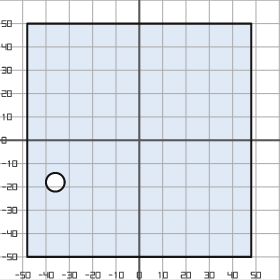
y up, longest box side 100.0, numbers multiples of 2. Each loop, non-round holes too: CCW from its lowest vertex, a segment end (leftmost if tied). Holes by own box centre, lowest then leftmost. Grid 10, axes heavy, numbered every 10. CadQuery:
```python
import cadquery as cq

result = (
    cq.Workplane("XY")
    .moveTo(-48.0, -50.0)
    .lineTo(48.0, -50.0)
    .lineTo(48.0, 50.0)
    .lineTo(-48.0, 50.0)
    .close()
    .moveTo(-36.0, -18.0)
    .circle(4.0)
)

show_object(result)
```